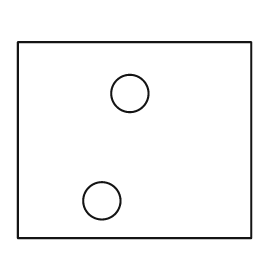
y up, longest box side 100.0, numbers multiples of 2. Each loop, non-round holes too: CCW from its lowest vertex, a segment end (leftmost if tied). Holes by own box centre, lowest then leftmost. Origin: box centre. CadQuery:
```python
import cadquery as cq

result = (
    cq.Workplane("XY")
    .moveTo(-50.0, -42.0)
    .lineTo(50.0, -42.0)
    .lineTo(50.0, 42.0)
    .lineTo(-50.0, 42.0)
    .close()
    .moveTo(-14.0, -26.0)
    .circle(8.0)
    .moveTo(-2.0, 20.0)
    .circle(8.0)
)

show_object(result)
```